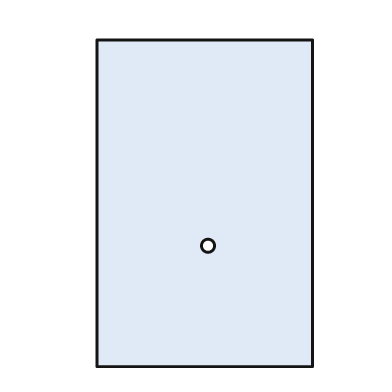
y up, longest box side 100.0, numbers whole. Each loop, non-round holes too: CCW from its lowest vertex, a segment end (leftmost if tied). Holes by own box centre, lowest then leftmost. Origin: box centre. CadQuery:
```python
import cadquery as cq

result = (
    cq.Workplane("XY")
    .moveTo(-33.0, -50.0)
    .lineTo(33.0, -50.0)
    .lineTo(33.0, 50.0)
    .lineTo(-33.0, 50.0)
    .close()
    .moveTo(1.0, -13.0)
    .circle(2.0)
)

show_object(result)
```